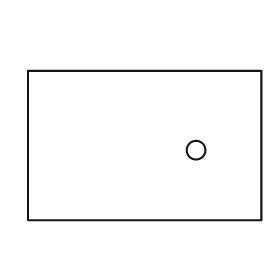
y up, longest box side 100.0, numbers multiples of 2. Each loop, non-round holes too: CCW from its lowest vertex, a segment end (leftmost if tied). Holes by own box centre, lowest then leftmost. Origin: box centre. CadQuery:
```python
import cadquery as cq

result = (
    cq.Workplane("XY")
    .moveTo(-50.0, -32.0)
    .lineTo(50.0, -32.0)
    .lineTo(50.0, 32.0)
    .lineTo(-50.0, 32.0)
    .close()
    .moveTo(22.0, -2.0)
    .circle(4.0)
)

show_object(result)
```